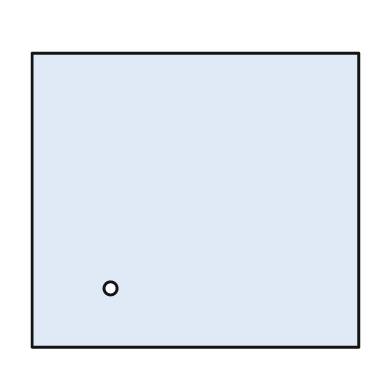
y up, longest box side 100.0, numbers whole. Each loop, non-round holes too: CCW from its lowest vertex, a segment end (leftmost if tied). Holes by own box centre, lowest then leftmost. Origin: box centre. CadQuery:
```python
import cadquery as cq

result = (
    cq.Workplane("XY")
    .moveTo(-50.0, -45.0)
    .lineTo(50.0, -45.0)
    .lineTo(50.0, 45.0)
    .lineTo(-50.0, 45.0)
    .close()
    .moveTo(-26.0, -27.0)
    .circle(2.0)
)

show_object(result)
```